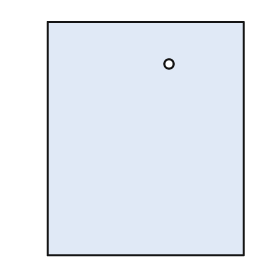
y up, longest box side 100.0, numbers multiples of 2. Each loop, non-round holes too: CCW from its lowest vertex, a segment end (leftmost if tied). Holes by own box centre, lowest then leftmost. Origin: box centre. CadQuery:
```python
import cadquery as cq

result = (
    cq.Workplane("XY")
    .moveTo(-42.0, -50.0)
    .lineTo(42.0, -50.0)
    .lineTo(42.0, 50.0)
    .lineTo(-42.0, 50.0)
    .close()
    .moveTo(10.0, 32.0)
    .circle(2.0)
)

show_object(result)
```